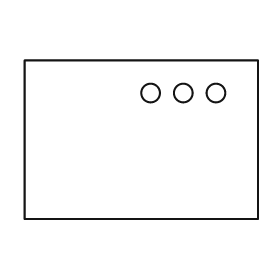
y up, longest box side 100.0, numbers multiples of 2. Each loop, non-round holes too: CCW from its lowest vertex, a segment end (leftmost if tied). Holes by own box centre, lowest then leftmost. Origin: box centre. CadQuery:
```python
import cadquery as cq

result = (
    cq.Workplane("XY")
    .moveTo(-50.0, -34.0)
    .lineTo(50.0, -34.0)
    .lineTo(50.0, 34.0)
    .lineTo(-50.0, 34.0)
    .close()
    .moveTo(4.0, 20.0)
    .circle(4.0)
    .moveTo(18.0, 20.0)
    .circle(4.0)
    .moveTo(32.0, 20.0)
    .circle(4.0)
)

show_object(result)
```